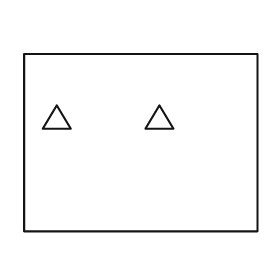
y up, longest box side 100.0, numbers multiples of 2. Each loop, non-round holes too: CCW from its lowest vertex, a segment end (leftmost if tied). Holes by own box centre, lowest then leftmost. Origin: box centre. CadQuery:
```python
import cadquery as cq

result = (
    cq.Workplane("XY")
    .moveTo(-50.0, -38.0)
    .lineTo(50.0, -38.0)
    .lineTo(50.0, 38.0)
    .lineTo(-50.0, 38.0)
    .close()
    .moveTo(-42.0, 6.0)
    .lineTo(-30.0, 6.0)
    .lineTo(-36.0, 16.0)
    .close()
    .moveTo(2.0, 6.0)
    .lineTo(14.0, 6.0)
    .lineTo(8.0, 16.0)
    .close()
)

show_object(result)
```